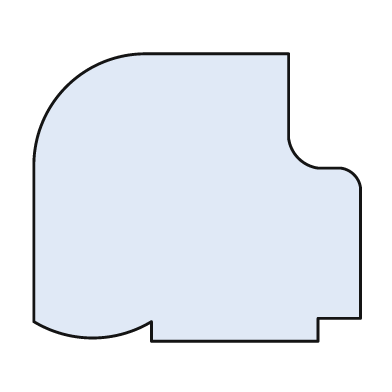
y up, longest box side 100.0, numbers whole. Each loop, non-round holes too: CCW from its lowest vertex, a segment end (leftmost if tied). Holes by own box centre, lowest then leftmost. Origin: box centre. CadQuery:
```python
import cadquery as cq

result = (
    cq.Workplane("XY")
    .moveTo(-14.0, -44.0)
    .lineTo(37.0, -44.0)
    .lineTo(37.0, -37.0)
    .lineTo(50.0, -37.0)
    .lineTo(50.0, 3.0)
    .threePointArc((48.0, 7.0), (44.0, 9.0))
    .lineTo(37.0, 9.0)
    .threePointArc((31.0, 12.0), (28.0, 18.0))
    .lineTo(28.0, 44.0)
    .lineTo(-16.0, 44.0)
    .threePointArc((-40.0, 34.0), (-50.0, 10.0))
    .lineTo(-50.0, -38.0)
    .threePointArc((-32.0, -43.0), (-14.0, -38.0))
    .close()
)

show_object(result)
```